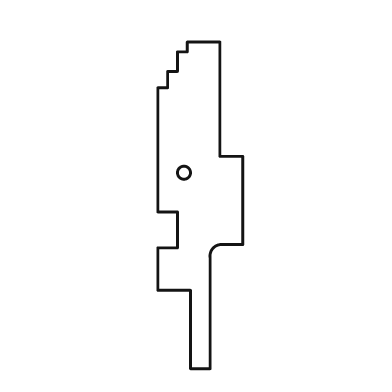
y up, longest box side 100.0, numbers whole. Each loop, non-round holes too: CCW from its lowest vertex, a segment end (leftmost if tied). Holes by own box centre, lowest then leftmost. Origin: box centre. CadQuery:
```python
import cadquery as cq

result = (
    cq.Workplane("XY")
    .moveTo(-3.0, -50.0)
    .lineTo(3.0, -50.0)
    .lineTo(3.0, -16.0)
    .threePointArc((4.0, -13.0), (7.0, -12.0))
    .lineTo(13.0, -12.0)
    .lineTo(13.0, 15.0)
    .lineTo(6.0, 15.0)
    .lineTo(6.0, 50.0)
    .lineTo(-4.0, 50.0)
    .lineTo(-4.0, 47.0)
    .lineTo(-7.0, 47.0)
    .lineTo(-7.0, 41.0)
    .lineTo(-10.0, 41.0)
    .lineTo(-10.0, 36.0)
    .lineTo(-13.0, 36.0)
    .lineTo(-13.0, -2.0)
    .lineTo(-7.0, -2.0)
    .lineTo(-7.0, -13.0)
    .lineTo(-13.0, -13.0)
    .lineTo(-13.0, -26.0)
    .lineTo(-3.0, -26.0)
    .close()
    .moveTo(-5.0, 10.0)
    .circle(2.0)
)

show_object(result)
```